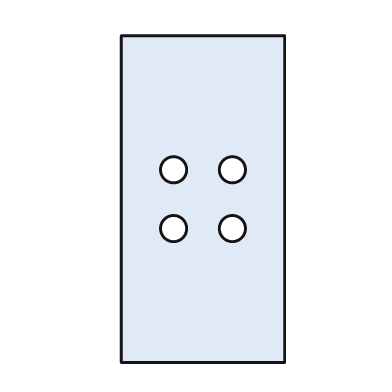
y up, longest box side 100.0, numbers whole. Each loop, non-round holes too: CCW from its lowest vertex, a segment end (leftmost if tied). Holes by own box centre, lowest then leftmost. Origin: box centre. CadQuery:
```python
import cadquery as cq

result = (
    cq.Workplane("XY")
    .moveTo(-25.0, -50.0)
    .lineTo(25.0, -50.0)
    .lineTo(25.0, 50.0)
    .lineTo(-25.0, 50.0)
    .close()
    .moveTo(-9.0, -9.0)
    .circle(4.0)
    .moveTo(9.0, -9.0)
    .circle(4.0)
    .moveTo(-9.0, 9.0)
    .circle(4.0)
    .moveTo(9.0, 9.0)
    .circle(4.0)
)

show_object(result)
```